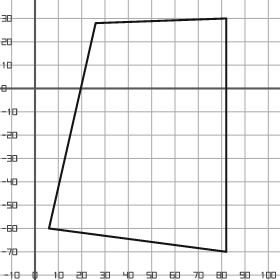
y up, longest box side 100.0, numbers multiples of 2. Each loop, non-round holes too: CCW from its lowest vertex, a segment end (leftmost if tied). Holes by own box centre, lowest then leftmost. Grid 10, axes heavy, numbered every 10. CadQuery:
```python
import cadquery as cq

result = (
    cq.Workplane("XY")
    .moveTo(82.0, -70.0)
    .lineTo(82.0, 30.0)
    .lineTo(26.0, 28.0)
    .lineTo(6.0, -60.0)
    .close()
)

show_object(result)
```